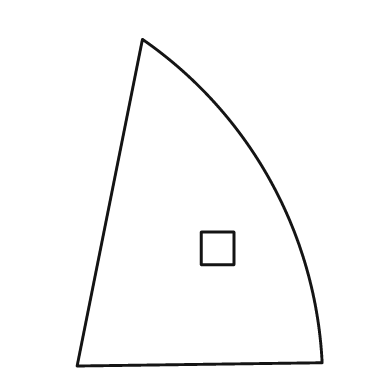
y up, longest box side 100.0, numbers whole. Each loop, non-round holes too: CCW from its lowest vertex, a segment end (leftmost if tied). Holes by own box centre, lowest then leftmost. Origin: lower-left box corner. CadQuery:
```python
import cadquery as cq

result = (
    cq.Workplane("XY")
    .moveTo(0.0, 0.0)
    .lineTo(75.0, 1.0)
    .threePointArc((59.0, 57.0), (20.0, 100.0))
    .close()
    .moveTo(38.0, 31.0)
    .lineTo(48.0, 31.0)
    .lineTo(48.0, 41.0)
    .lineTo(38.0, 41.0)
    .close()
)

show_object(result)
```